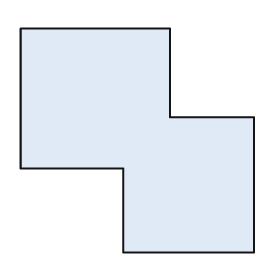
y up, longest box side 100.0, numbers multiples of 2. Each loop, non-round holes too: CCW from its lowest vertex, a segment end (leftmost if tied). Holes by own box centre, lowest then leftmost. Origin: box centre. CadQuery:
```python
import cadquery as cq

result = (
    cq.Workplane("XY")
    .moveTo(-6.0, -48.0)
    .lineTo(50.0, -48.0)
    .lineTo(50.0, 10.0)
    .lineTo(14.0, 10.0)
    .lineTo(14.0, 48.0)
    .lineTo(-50.0, 48.0)
    .lineTo(-50.0, -12.0)
    .lineTo(-6.0, -12.0)
    .close()
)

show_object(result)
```